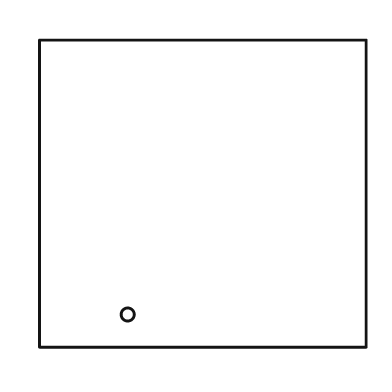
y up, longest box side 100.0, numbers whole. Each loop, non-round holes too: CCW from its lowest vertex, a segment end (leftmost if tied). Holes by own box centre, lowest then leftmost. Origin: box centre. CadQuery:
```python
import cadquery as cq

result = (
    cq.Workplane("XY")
    .moveTo(-50.0, -47.0)
    .lineTo(50.0, -47.0)
    .lineTo(50.0, 47.0)
    .lineTo(-50.0, 47.0)
    .close()
    .moveTo(-23.0, -37.0)
    .circle(2.0)
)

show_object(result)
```